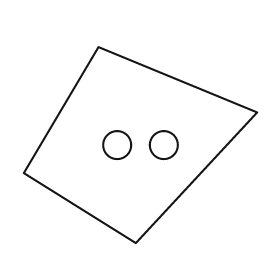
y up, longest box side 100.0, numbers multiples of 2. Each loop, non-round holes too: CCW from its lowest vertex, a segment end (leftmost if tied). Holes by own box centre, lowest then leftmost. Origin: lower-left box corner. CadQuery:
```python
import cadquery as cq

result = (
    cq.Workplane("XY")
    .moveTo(48.0, 0.0)
    .lineTo(100.0, 56.0)
    .lineTo(32.0, 84.0)
    .lineTo(0.0, 30.0)
    .close()
    .moveTo(40.0, 42.0)
    .circle(6.0)
    .moveTo(60.0, 42.0)
    .circle(6.0)
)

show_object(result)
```